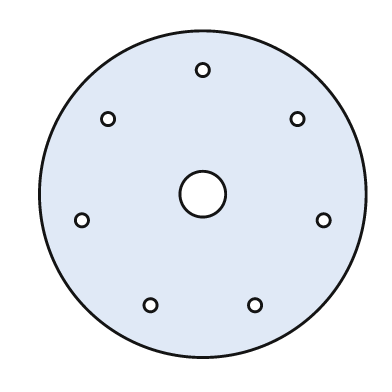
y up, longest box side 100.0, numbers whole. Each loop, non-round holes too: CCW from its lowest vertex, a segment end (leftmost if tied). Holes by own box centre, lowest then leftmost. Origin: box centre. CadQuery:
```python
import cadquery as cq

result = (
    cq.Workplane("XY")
    .moveTo(0.0, 0.0)
    .circle(50.0)
    .moveTo(-16.0, -34.0)
    .circle(2.0)
    .moveTo(16.0, -34.0)
    .circle(2.0)
    .moveTo(-37.0, -8.0)
    .circle(2.0)
    .moveTo(37.0, -8.0)
    .circle(2.0)
    .moveTo(0.0, 0.0)
    .circle(7.0)
    .moveTo(-29.0, 23.0)
    .circle(2.0)
    .moveTo(29.0, 23.0)
    .circle(2.0)
    .moveTo(0.0, 38.0)
    .circle(2.0)
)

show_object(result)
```